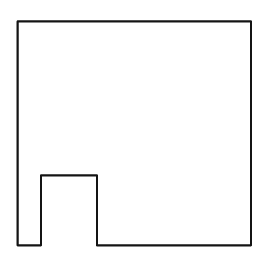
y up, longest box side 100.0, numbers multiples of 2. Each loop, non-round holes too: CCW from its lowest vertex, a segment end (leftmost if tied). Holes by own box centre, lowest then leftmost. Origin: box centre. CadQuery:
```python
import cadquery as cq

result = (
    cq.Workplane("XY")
    .moveTo(-50.0, -48.0)
    .lineTo(-40.0, -48.0)
    .lineTo(-40.0, -18.0)
    .lineTo(-16.0, -18.0)
    .lineTo(-16.0, -48.0)
    .lineTo(50.0, -48.0)
    .lineTo(50.0, 48.0)
    .lineTo(-50.0, 48.0)
    .close()
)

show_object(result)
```